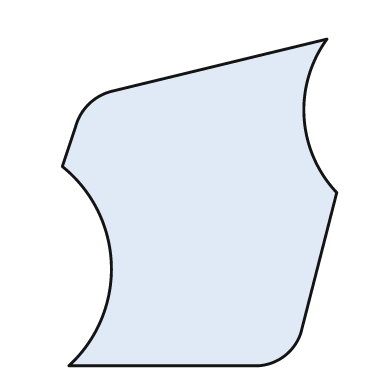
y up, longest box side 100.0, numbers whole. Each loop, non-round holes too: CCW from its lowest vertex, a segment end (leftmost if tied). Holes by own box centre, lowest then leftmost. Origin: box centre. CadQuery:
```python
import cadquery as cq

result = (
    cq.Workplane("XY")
    .moveTo(-40.0, -50.0)
    .lineTo(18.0, -50.0)
    .threePointArc((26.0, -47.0), (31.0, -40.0))
    .lineTo(42.0, 3.0)
    .threePointArc((32.0, 26.0), (39.0, 50.0))
    .lineTo(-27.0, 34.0)
    .threePointArc((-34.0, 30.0), (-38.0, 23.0))
    .lineTo(-42.0, 11.0)
    .threePointArc((-27.0, -19.0), (-40.0, -50.0))
    .close()
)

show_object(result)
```